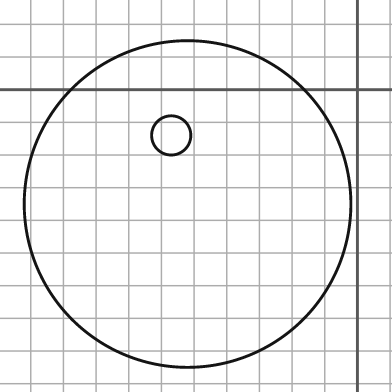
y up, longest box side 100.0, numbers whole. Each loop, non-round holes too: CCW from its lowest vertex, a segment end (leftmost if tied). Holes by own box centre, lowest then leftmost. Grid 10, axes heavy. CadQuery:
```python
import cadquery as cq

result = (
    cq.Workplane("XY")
    .moveTo(-52.0, -35.0)
    .circle(50.0)
    .moveTo(-57.0, -14.0)
    .circle(6.0)
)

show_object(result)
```